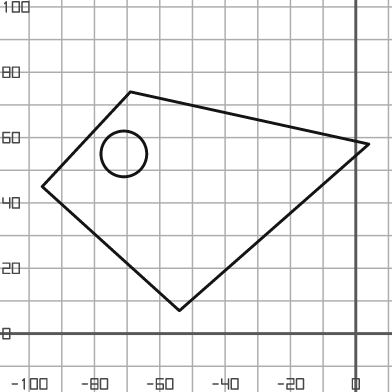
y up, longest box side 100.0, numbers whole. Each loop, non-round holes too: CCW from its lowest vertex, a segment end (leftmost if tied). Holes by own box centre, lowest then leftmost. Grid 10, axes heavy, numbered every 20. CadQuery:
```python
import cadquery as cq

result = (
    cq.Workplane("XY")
    .moveTo(-54.0, 7.0)
    .lineTo(4.0, 58.0)
    .lineTo(-69.0, 74.0)
    .lineTo(-96.0, 45.0)
    .close()
    .moveTo(-71.0, 55.0)
    .circle(7.0)
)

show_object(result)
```